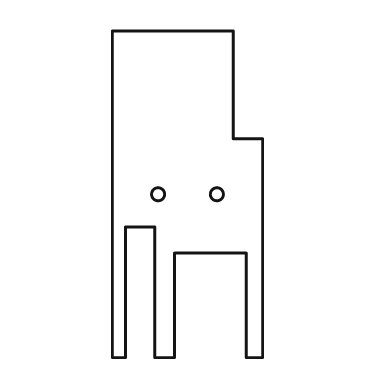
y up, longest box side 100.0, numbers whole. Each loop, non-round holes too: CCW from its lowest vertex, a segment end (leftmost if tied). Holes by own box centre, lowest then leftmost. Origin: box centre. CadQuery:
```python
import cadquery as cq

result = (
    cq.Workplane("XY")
    .moveTo(-23.0, -50.0)
    .lineTo(-19.0, -50.0)
    .lineTo(-19.0, -10.0)
    .lineTo(-10.0, -10.0)
    .lineTo(-10.0, -50.0)
    .lineTo(-4.0, -50.0)
    .lineTo(-4.0, -18.0)
    .lineTo(18.0, -18.0)
    .lineTo(18.0, -50.0)
    .lineTo(23.0, -50.0)
    .lineTo(23.0, 17.0)
    .lineTo(14.0, 17.0)
    .lineTo(14.0, 50.0)
    .lineTo(-23.0, 50.0)
    .close()
    .moveTo(-9.0, 0.0)
    .circle(2.0)
    .moveTo(9.0, 0.0)
    .circle(2.0)
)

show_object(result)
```